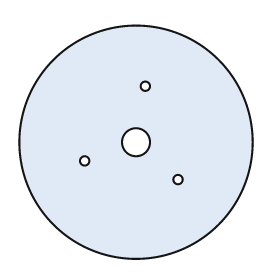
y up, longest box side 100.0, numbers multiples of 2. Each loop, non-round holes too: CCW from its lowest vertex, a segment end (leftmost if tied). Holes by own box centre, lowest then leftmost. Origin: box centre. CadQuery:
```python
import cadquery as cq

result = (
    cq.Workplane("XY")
    .moveTo(0.0, 0.0)
    .circle(50.0)
    .moveTo(18.0, -16.0)
    .circle(2.0)
    .moveTo(-22.0, -8.0)
    .circle(2.0)
    .moveTo(0.0, 0.0)
    .circle(6.0)
    .moveTo(4.0, 24.0)
    .circle(2.0)
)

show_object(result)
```